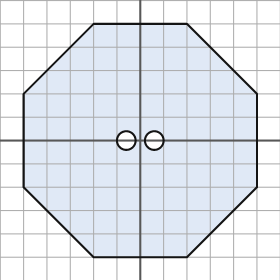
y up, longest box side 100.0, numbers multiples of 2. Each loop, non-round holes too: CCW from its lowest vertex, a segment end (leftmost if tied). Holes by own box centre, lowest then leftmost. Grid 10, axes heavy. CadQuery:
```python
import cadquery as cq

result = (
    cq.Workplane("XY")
    .moveTo(-20.0, -50.0)
    .lineTo(20.0, -50.0)
    .lineTo(50.0, -20.0)
    .lineTo(50.0, 20.0)
    .lineTo(20.0, 50.0)
    .lineTo(-20.0, 50.0)
    .lineTo(-50.0, 20.0)
    .lineTo(-50.0, -20.0)
    .close()
    .moveTo(-6.0, 0.0)
    .circle(4.0)
    .moveTo(6.0, 0.0)
    .circle(4.0)
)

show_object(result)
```